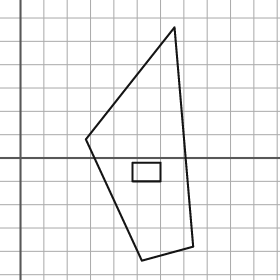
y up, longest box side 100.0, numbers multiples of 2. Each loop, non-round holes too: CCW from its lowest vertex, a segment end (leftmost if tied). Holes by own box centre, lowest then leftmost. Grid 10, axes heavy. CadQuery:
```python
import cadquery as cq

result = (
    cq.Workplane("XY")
    .moveTo(52.0, -44.0)
    .lineTo(74.0, -38.0)
    .lineTo(66.0, 56.0)
    .lineTo(28.0, 8.0)
    .close()
    .moveTo(48.0, -10.0)
    .lineTo(60.0, -10.0)
    .lineTo(60.0, -2.0)
    .lineTo(48.0, -2.0)
    .close()
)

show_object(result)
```